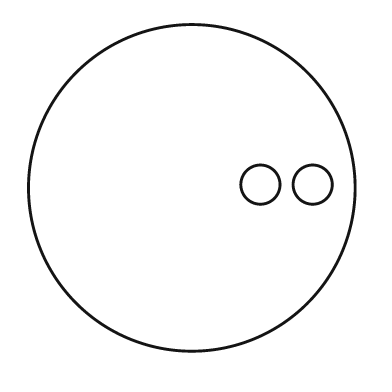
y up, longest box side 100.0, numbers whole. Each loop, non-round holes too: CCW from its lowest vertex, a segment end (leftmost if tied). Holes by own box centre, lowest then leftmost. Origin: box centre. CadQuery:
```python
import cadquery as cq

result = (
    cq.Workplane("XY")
    .moveTo(0.0, 0.0)
    .circle(50.0)
    .moveTo(21.0, 1.0)
    .circle(6.0)
    .moveTo(37.0, 1.0)
    .circle(6.0)
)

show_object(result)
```